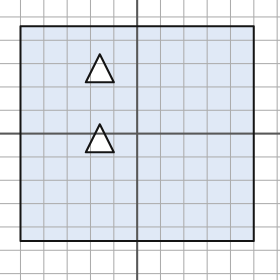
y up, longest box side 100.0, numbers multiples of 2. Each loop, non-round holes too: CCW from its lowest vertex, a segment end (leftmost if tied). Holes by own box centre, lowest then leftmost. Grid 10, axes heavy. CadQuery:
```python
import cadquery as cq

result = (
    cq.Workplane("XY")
    .moveTo(-50.0, -46.0)
    .lineTo(50.0, -46.0)
    .lineTo(50.0, 46.0)
    .lineTo(-50.0, 46.0)
    .close()
    .moveTo(-22.0, -8.0)
    .lineTo(-10.0, -8.0)
    .lineTo(-16.0, 4.0)
    .close()
    .moveTo(-22.0, 22.0)
    .lineTo(-10.0, 22.0)
    .lineTo(-16.0, 34.0)
    .close()
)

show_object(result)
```